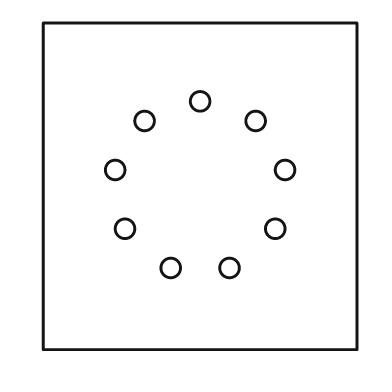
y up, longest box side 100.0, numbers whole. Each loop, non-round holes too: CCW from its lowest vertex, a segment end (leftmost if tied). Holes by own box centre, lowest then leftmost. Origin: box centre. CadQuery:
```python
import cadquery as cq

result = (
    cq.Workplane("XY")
    .moveTo(-48.0, -50.0)
    .lineTo(48.0, -50.0)
    .lineTo(48.0, 50.0)
    .lineTo(-48.0, 50.0)
    .close()
    .moveTo(-9.0, -25.0)
    .circle(3.0)
    .moveTo(9.0, -25.0)
    .circle(3.0)
    .moveTo(-23.0, -13.0)
    .circle(3.0)
    .moveTo(23.0, -13.0)
    .circle(3.0)
    .moveTo(-26.0, 5.0)
    .circle(3.0)
    .moveTo(26.0, 5.0)
    .circle(3.0)
    .moveTo(-17.0, 20.0)
    .circle(3.0)
    .moveTo(17.0, 20.0)
    .circle(3.0)
    .moveTo(0.0, 26.0)
    .circle(3.0)
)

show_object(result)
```